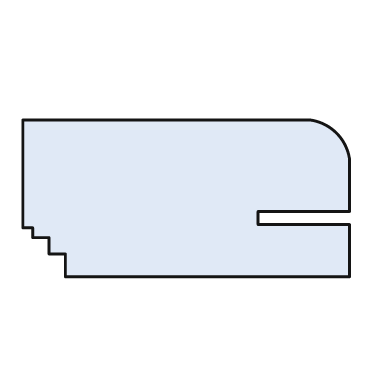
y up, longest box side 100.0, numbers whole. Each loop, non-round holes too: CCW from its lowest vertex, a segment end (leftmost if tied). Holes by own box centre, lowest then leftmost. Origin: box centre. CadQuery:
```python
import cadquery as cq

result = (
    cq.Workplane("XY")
    .moveTo(-37.0, -24.0)
    .lineTo(50.0, -24.0)
    .lineTo(50.0, -8.0)
    .lineTo(22.0, -8.0)
    .lineTo(22.0, -4.0)
    .lineTo(50.0, -4.0)
    .lineTo(50.0, 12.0)
    .threePointArc((46.0, 20.0), (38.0, 24.0))
    .lineTo(-50.0, 24.0)
    .lineTo(-50.0, -9.0)
    .lineTo(-47.0, -9.0)
    .lineTo(-47.0, -12.0)
    .lineTo(-42.0, -12.0)
    .lineTo(-42.0, -17.0)
    .lineTo(-37.0, -17.0)
    .close()
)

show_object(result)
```